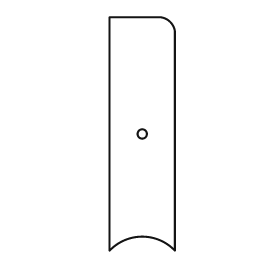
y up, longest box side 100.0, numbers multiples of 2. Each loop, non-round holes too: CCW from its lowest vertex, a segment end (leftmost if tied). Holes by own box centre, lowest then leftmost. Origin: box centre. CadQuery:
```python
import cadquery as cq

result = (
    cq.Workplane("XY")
    .moveTo(-14.0, -50.0)
    .threePointArc((0.0, -44.0), (14.0, -50.0))
    .lineTo(14.0, 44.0)
    .threePointArc((12.0, 48.0), (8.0, 50.0))
    .lineTo(-14.0, 50.0)
    .close()
    .moveTo(0.0, 0.0)
    .circle(2.0)
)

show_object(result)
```